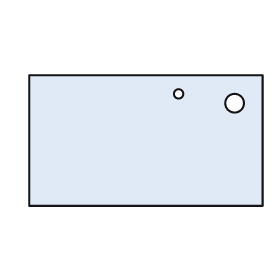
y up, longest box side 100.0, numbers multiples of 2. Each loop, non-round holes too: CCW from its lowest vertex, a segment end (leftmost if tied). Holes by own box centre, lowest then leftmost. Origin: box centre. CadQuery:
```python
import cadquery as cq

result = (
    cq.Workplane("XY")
    .moveTo(-50.0, -28.0)
    .lineTo(50.0, -28.0)
    .lineTo(50.0, 28.0)
    .lineTo(-50.0, 28.0)
    .close()
    .moveTo(38.0, 16.0)
    .circle(4.0)
    .moveTo(14.0, 20.0)
    .circle(2.0)
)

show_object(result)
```